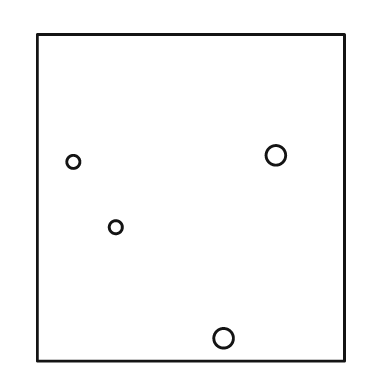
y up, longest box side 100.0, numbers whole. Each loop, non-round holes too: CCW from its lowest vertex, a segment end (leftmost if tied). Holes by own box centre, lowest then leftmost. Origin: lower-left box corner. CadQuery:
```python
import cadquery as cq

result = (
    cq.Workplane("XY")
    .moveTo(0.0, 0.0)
    .lineTo(94.0, 0.0)
    .lineTo(94.0, 100.0)
    .lineTo(0.0, 100.0)
    .close()
    .moveTo(57.0, 7.0)
    .circle(3.0)
    .moveTo(24.0, 41.0)
    .circle(2.0)
    .moveTo(11.0, 61.0)
    .circle(2.0)
    .moveTo(73.0, 63.0)
    .circle(3.0)
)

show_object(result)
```